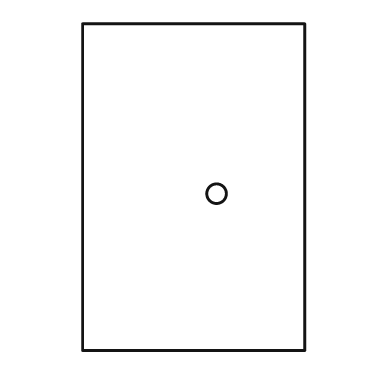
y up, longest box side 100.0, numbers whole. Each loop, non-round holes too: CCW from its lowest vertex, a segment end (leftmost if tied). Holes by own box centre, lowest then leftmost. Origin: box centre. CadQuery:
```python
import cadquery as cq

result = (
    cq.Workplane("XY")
    .moveTo(-34.0, -50.0)
    .lineTo(34.0, -50.0)
    .lineTo(34.0, 50.0)
    .lineTo(-34.0, 50.0)
    .close()
    .moveTo(7.0, -2.0)
    .circle(3.0)
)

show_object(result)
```